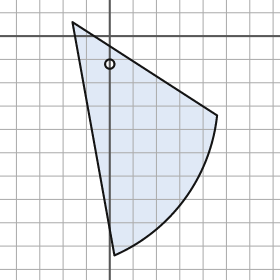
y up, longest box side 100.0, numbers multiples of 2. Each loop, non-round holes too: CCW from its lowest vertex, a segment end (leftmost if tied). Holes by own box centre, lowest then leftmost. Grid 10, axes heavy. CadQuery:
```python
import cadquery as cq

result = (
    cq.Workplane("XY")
    .moveTo(2.0, -94.0)
    .threePointArc((32.0, -70.0), (46.0, -34.0))
    .lineTo(-16.0, 6.0)
    .close()
    .moveTo(0.0, -12.0)
    .circle(2.0)
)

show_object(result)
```